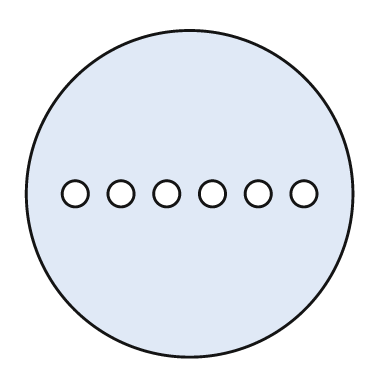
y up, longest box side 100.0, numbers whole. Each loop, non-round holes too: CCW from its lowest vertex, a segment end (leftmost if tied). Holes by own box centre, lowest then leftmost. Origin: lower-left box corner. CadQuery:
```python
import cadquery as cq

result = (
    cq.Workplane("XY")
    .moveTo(50.0, 50.0)
    .circle(50.0)
    .moveTo(15.0, 50.0)
    .circle(4.0)
    .moveTo(29.0, 50.0)
    .circle(4.0)
    .moveTo(43.0, 50.0)
    .circle(4.0)
    .moveTo(57.0, 50.0)
    .circle(4.0)
    .moveTo(71.0, 50.0)
    .circle(4.0)
    .moveTo(85.0, 50.0)
    .circle(4.0)
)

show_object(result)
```